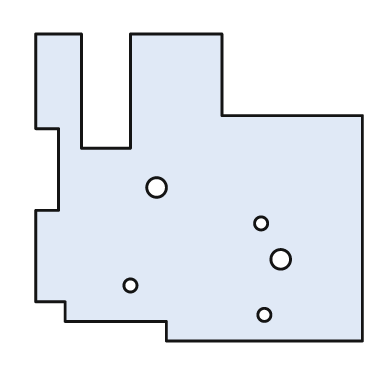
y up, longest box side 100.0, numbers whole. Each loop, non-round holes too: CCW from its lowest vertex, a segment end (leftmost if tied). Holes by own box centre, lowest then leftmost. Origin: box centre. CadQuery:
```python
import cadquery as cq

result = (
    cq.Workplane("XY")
    .moveTo(-10.0, -47.0)
    .lineTo(50.0, -47.0)
    .lineTo(50.0, 22.0)
    .lineTo(7.0, 22.0)
    .lineTo(7.0, 47.0)
    .lineTo(-21.0, 47.0)
    .lineTo(-21.0, 12.0)
    .lineTo(-36.0, 12.0)
    .lineTo(-36.0, 47.0)
    .lineTo(-50.0, 47.0)
    .lineTo(-50.0, 18.0)
    .lineTo(-43.0, 18.0)
    .lineTo(-43.0, -7.0)
    .lineTo(-50.0, -7.0)
    .lineTo(-50.0, -35.0)
    .lineTo(-41.0, -35.0)
    .lineTo(-41.0, -41.0)
    .lineTo(-10.0, -41.0)
    .close()
    .moveTo(20.0, -39.0)
    .circle(2.0)
    .moveTo(-21.0, -30.0)
    .circle(2.0)
    .moveTo(25.0, -22.0)
    .circle(3.0)
    .moveTo(19.0, -11.0)
    .circle(2.0)
    .moveTo(-13.0, 0.0)
    .circle(3.0)
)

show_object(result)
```